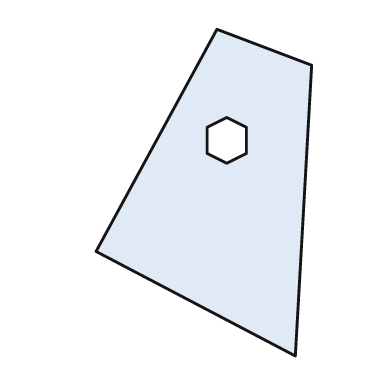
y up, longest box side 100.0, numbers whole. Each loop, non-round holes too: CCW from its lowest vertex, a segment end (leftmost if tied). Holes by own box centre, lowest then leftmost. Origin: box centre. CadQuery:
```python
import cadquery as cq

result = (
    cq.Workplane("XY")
    .moveTo(28.0, -50.0)
    .lineTo(33.0, 39.0)
    .lineTo(4.0, 50.0)
    .lineTo(-33.0, -18.0)
    .close()
    .moveTo(7.0, 9.0)
    .lineTo(13.0, 12.0)
    .lineTo(13.0, 20.0)
    .lineTo(7.0, 23.0)
    .lineTo(1.0, 20.0)
    .lineTo(1.0, 12.0)
    .close()
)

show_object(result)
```